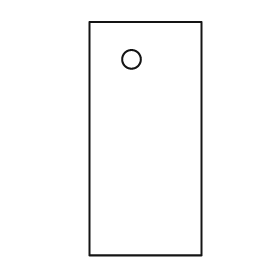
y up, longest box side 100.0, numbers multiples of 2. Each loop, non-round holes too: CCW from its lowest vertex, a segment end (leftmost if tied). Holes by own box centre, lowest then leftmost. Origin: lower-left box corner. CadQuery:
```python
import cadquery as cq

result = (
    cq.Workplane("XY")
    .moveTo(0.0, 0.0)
    .lineTo(48.0, 0.0)
    .lineTo(48.0, 100.0)
    .lineTo(0.0, 100.0)
    .close()
    .moveTo(18.0, 84.0)
    .circle(4.0)
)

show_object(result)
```